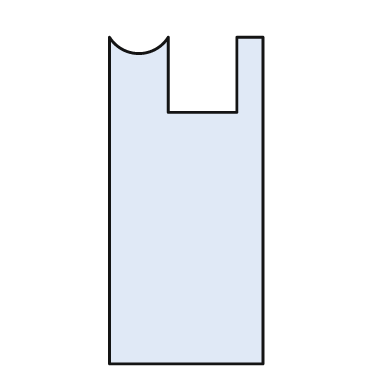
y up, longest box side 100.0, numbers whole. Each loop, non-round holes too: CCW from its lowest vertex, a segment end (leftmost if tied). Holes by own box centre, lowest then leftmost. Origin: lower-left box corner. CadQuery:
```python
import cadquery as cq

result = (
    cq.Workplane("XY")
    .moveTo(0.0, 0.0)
    .lineTo(47.0, 0.0)
    .lineTo(47.0, 100.0)
    .lineTo(39.0, 100.0)
    .lineTo(39.0, 77.0)
    .lineTo(18.0, 77.0)
    .lineTo(18.0, 100.0)
    .threePointArc((9.0, 95.0), (0.0, 100.0))
    .close()
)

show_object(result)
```